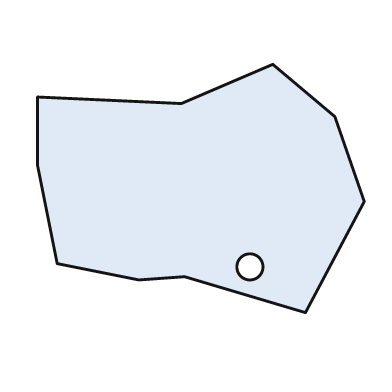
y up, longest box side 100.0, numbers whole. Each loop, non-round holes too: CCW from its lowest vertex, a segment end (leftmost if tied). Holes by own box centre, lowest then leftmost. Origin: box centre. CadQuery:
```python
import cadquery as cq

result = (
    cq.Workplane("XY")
    .moveTo(32.0, -38.0)
    .lineTo(50.0, -4.0)
    .lineTo(41.0, 22.0)
    .lineTo(22.0, 38.0)
    .lineTo(-6.0, 26.0)
    .lineTo(-50.0, 28.0)
    .lineTo(-50.0, 7.0)
    .lineTo(-44.0, -23.0)
    .lineTo(-19.0, -28.0)
    .lineTo(-5.0, -27.0)
    .close()
    .moveTo(15.0, -24.0)
    .circle(4.0)
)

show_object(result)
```